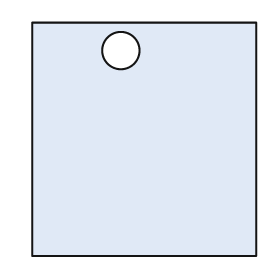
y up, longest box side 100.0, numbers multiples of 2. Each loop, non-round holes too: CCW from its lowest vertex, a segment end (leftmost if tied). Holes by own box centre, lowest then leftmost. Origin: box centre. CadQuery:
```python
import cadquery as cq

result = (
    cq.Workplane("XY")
    .moveTo(-48.0, -50.0)
    .lineTo(48.0, -50.0)
    .lineTo(48.0, 50.0)
    .lineTo(-48.0, 50.0)
    .close()
    .moveTo(-10.0, 38.0)
    .circle(8.0)
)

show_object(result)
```